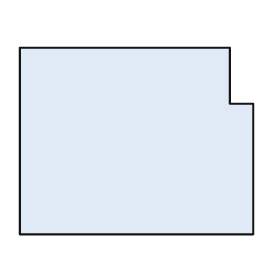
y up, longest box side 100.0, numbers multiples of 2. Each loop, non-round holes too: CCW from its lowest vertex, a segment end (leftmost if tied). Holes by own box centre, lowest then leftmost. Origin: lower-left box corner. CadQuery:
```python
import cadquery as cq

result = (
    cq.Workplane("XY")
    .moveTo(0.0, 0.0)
    .lineTo(100.0, 0.0)
    .lineTo(100.0, 56.0)
    .lineTo(90.0, 56.0)
    .lineTo(90.0, 80.0)
    .lineTo(0.0, 80.0)
    .close()
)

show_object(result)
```